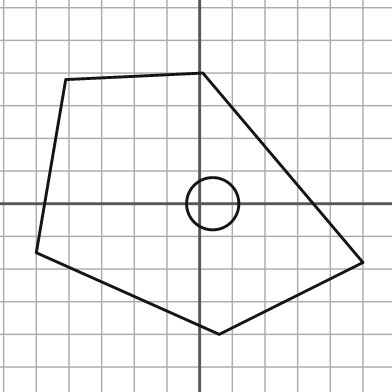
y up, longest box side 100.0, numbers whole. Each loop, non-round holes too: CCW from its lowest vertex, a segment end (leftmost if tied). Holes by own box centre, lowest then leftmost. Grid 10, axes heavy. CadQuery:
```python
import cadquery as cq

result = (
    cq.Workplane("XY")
    .moveTo(6.0, -40.0)
    .lineTo(50.0, -18.0)
    .lineTo(1.0, 40.0)
    .lineTo(-41.0, 38.0)
    .lineTo(-50.0, -15.0)
    .close()
    .moveTo(4.0, 0.0)
    .circle(8.0)
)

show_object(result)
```